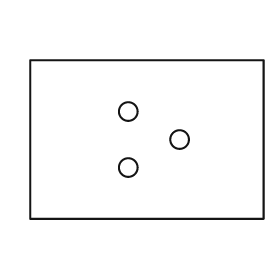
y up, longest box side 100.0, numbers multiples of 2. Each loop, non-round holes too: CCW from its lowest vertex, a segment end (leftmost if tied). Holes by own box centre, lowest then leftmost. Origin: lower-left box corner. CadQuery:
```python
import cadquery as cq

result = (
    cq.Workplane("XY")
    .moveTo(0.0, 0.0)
    .lineTo(100.0, 0.0)
    .lineTo(100.0, 68.0)
    .lineTo(0.0, 68.0)
    .close()
    .moveTo(42.0, 22.0)
    .circle(4.0)
    .moveTo(64.0, 34.0)
    .circle(4.0)
    .moveTo(42.0, 46.0)
    .circle(4.0)
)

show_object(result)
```